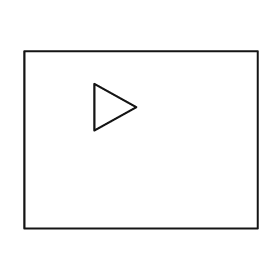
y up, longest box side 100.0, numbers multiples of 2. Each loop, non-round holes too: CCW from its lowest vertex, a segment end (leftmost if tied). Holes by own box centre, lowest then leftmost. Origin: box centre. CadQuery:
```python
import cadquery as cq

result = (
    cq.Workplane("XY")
    .moveTo(-50.0, -38.0)
    .lineTo(50.0, -38.0)
    .lineTo(50.0, 38.0)
    .lineTo(-50.0, 38.0)
    .close()
    .moveTo(-20.0, 4.0)
    .lineTo(-2.0, 14.0)
    .lineTo(-20.0, 24.0)
    .close()
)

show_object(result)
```